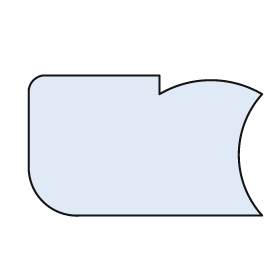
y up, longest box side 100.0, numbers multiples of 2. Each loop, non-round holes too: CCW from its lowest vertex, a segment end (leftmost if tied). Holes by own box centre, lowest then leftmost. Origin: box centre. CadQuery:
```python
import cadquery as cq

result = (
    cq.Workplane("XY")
    .moveTo(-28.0, -30.0)
    .lineTo(50.0, -30.0)
    .threePointArc((40.0, -4.0), (50.0, 22.0))
    .threePointArc((28.0, 28.0), (6.0, 22.0))
    .lineTo(6.0, 30.0)
    .lineTo(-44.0, 30.0)
    .threePointArc((-48.0, 28.0), (-50.0, 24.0))
    .lineTo(-50.0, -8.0)
    .threePointArc((-44.0, -24.0), (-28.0, -30.0))
    .close()
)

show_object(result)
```